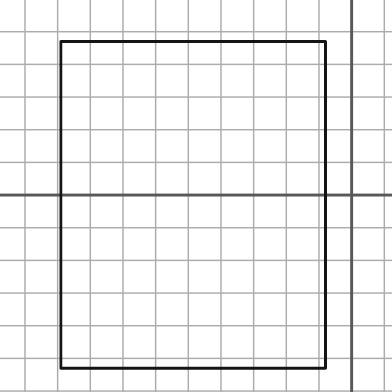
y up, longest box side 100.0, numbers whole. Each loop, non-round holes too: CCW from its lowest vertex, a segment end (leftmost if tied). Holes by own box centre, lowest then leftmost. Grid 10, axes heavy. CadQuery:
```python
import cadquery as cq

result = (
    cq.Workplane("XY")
    .moveTo(-89.0, -53.0)
    .lineTo(-8.0, -53.0)
    .lineTo(-8.0, 47.0)
    .lineTo(-89.0, 47.0)
    .close()
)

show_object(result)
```